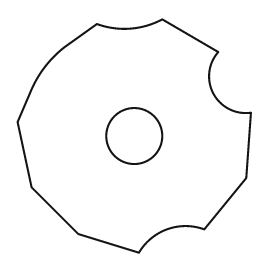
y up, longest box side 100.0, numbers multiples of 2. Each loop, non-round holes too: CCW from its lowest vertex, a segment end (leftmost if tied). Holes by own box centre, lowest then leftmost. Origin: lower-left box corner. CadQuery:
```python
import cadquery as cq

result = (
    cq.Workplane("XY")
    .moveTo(52.0, 0.0)
    .threePointArc((64.0, 10.0), (80.0, 10.0))
    .lineTo(98.0, 32.0)
    .lineTo(100.0, 60.0)
    .threePointArc((84.0, 68.0), (86.0, 86.0))
    .lineTo(62.0, 100.0)
    .threePointArc((48.0, 96.0), (34.0, 98.0))
    .lineTo(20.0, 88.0)
    .threePointArc((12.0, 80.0), (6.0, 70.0))
    .lineTo(0.0, 56.0)
    .lineTo(6.0, 28.0)
    .lineTo(26.0, 8.0)
    .close()
    .moveTo(50.0, 50.0)
    .circle(12.0)
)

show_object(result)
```